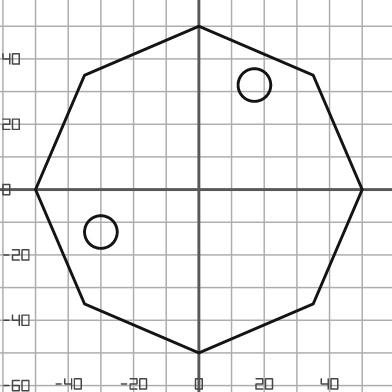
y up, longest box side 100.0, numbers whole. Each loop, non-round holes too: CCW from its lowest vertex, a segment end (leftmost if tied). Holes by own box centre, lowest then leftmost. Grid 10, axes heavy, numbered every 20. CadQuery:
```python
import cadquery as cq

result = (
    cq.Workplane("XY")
    .moveTo(0.0, -50.0)
    .lineTo(35.0, -35.0)
    .lineTo(50.0, 0.0)
    .lineTo(35.0, 35.0)
    .lineTo(0.0, 50.0)
    .lineTo(-35.0, 35.0)
    .lineTo(-50.0, 0.0)
    .lineTo(-35.0, -35.0)
    .close()
    .moveTo(-30.0, -13.0)
    .circle(5.0)
    .moveTo(17.0, 32.0)
    .circle(5.0)
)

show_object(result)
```